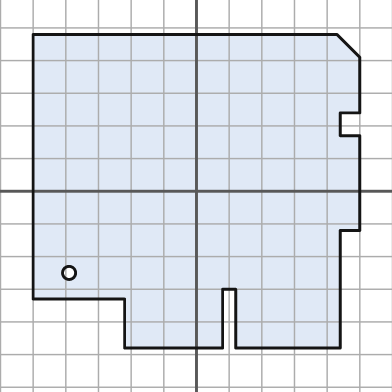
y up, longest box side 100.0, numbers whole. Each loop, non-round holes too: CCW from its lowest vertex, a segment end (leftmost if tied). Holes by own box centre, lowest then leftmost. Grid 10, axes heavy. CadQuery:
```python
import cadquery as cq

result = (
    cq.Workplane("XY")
    .moveTo(-22.0, -48.0)
    .lineTo(8.0, -48.0)
    .lineTo(8.0, -30.0)
    .lineTo(12.0, -30.0)
    .lineTo(12.0, -48.0)
    .lineTo(44.0, -48.0)
    .lineTo(44.0, -12.0)
    .lineTo(50.0, -12.0)
    .lineTo(50.0, 17.0)
    .lineTo(44.0, 17.0)
    .lineTo(44.0, 24.0)
    .lineTo(50.0, 24.0)
    .lineTo(50.0, 41.0)
    .lineTo(43.0, 48.0)
    .lineTo(-50.0, 48.0)
    .lineTo(-50.0, -33.0)
    .lineTo(-22.0, -33.0)
    .close()
    .moveTo(-39.0, -25.0)
    .circle(2.0)
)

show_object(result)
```